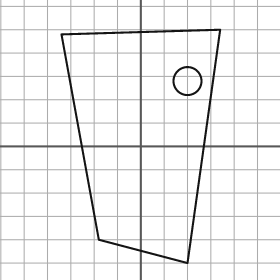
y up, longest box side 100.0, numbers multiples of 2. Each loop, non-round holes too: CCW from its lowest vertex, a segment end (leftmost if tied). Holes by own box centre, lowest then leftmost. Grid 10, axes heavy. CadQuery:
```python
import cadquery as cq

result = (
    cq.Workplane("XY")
    .moveTo(20.0, -50.0)
    .lineTo(34.0, 50.0)
    .lineTo(-34.0, 48.0)
    .lineTo(-18.0, -40.0)
    .close()
    .moveTo(20.0, 28.0)
    .circle(6.0)
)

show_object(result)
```